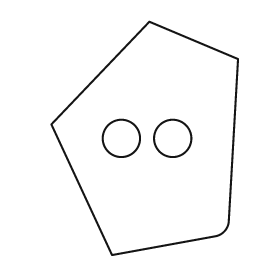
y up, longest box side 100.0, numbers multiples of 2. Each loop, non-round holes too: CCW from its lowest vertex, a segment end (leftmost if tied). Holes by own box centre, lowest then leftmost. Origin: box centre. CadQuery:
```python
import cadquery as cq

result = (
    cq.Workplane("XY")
    .moveTo(-14.0, -50.0)
    .lineTo(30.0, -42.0)
    .threePointArc((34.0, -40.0), (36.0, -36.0))
    .lineTo(40.0, 34.0)
    .lineTo(2.0, 50.0)
    .lineTo(-40.0, 6.0)
    .close()
    .moveTo(-10.0, 0.0)
    .circle(8.0)
    .moveTo(12.0, 0.0)
    .circle(8.0)
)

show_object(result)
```